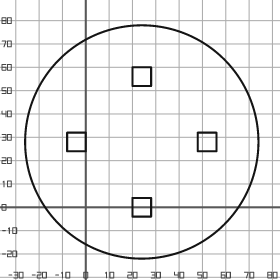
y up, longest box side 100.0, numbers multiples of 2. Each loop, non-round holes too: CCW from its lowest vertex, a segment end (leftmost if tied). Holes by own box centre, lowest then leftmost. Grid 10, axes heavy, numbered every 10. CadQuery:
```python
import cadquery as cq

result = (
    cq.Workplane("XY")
    .moveTo(24.0, 28.0)
    .circle(50.0)
    .moveTo(20.0, -4.0)
    .lineTo(28.0, -4.0)
    .lineTo(28.0, 4.0)
    .lineTo(20.0, 4.0)
    .close()
    .moveTo(-8.0, 24.0)
    .lineTo(0.0, 24.0)
    .lineTo(0.0, 32.0)
    .lineTo(-8.0, 32.0)
    .close()
    .moveTo(48.0, 24.0)
    .lineTo(56.0, 24.0)
    .lineTo(56.0, 32.0)
    .lineTo(48.0, 32.0)
    .close()
    .moveTo(20.0, 52.0)
    .lineTo(28.0, 52.0)
    .lineTo(28.0, 60.0)
    .lineTo(20.0, 60.0)
    .close()
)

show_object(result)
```